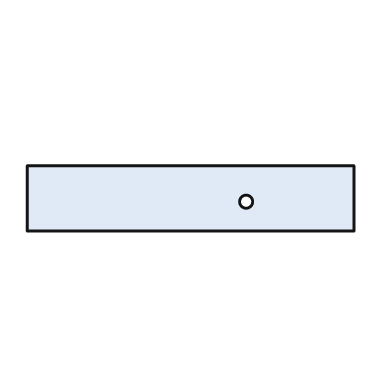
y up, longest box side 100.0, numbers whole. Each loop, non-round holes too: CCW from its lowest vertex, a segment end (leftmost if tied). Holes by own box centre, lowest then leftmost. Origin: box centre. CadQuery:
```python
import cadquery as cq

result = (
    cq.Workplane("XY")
    .moveTo(-50.0, -10.0)
    .lineTo(50.0, -10.0)
    .lineTo(50.0, 10.0)
    .lineTo(-50.0, 10.0)
    .close()
    .moveTo(17.0, -1.0)
    .circle(2.0)
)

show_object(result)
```